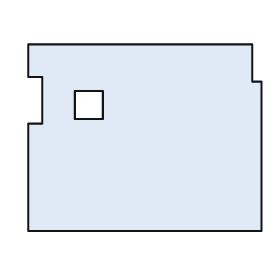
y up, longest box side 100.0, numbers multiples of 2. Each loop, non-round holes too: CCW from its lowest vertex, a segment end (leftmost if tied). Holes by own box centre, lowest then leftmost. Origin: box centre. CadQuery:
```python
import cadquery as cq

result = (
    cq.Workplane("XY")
    .moveTo(-50.0, -40.0)
    .lineTo(50.0, -40.0)
    .lineTo(50.0, 24.0)
    .lineTo(46.0, 24.0)
    .lineTo(46.0, 40.0)
    .lineTo(-50.0, 40.0)
    .lineTo(-50.0, 26.0)
    .lineTo(-44.0, 26.0)
    .lineTo(-44.0, 6.0)
    .lineTo(-50.0, 6.0)
    .close()
    .moveTo(-30.0, 8.0)
    .lineTo(-18.0, 8.0)
    .lineTo(-18.0, 20.0)
    .lineTo(-30.0, 20.0)
    .close()
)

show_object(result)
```